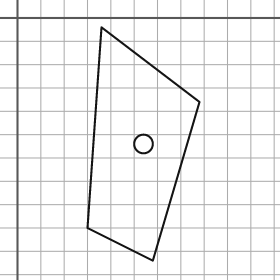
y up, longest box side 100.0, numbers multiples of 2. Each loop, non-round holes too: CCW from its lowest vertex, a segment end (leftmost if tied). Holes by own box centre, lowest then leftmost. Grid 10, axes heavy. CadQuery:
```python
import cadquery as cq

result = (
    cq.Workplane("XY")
    .moveTo(58.0, -104.0)
    .lineTo(78.0, -36.0)
    .lineTo(36.0, -4.0)
    .lineTo(30.0, -90.0)
    .close()
    .moveTo(54.0, -54.0)
    .circle(4.0)
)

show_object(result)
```